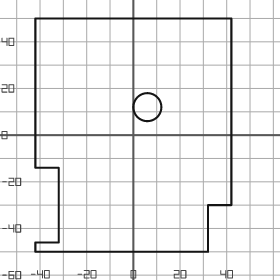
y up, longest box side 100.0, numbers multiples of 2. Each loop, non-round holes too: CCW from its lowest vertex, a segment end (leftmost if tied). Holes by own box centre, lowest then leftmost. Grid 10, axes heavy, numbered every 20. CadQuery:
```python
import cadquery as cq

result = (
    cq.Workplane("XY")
    .moveTo(-42.0, -50.0)
    .lineTo(32.0, -50.0)
    .lineTo(32.0, -30.0)
    .lineTo(42.0, -30.0)
    .lineTo(42.0, 50.0)
    .lineTo(-42.0, 50.0)
    .lineTo(-42.0, -14.0)
    .lineTo(-32.0, -14.0)
    .lineTo(-32.0, -46.0)
    .lineTo(-42.0, -46.0)
    .close()
    .moveTo(6.0, 12.0)
    .circle(6.0)
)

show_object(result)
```